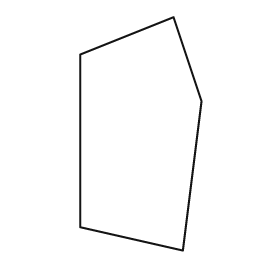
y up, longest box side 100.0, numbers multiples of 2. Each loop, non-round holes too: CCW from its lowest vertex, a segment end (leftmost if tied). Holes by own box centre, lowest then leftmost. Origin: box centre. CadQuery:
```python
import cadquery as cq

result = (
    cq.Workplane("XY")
    .moveTo(18.0, -50.0)
    .lineTo(26.0, 14.0)
    .lineTo(14.0, 50.0)
    .lineTo(-26.0, 34.0)
    .lineTo(-26.0, -40.0)
    .close()
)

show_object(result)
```